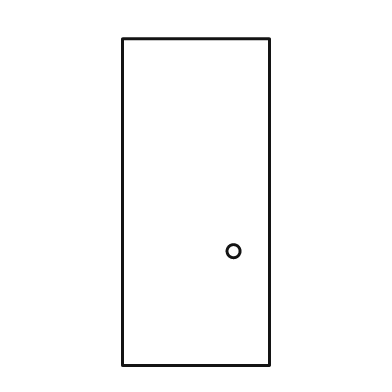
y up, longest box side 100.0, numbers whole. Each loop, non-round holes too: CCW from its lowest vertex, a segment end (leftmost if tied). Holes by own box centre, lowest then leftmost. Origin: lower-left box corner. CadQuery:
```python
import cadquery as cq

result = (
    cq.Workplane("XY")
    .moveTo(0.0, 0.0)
    .lineTo(45.0, 0.0)
    .lineTo(45.0, 100.0)
    .lineTo(0.0, 100.0)
    .close()
    .moveTo(34.0, 35.0)
    .circle(2.0)
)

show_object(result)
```